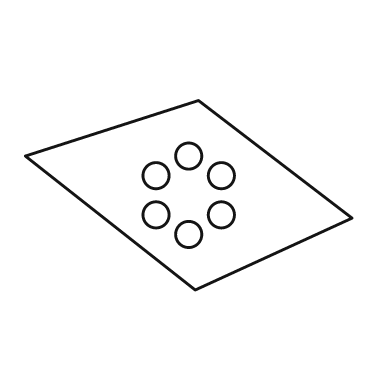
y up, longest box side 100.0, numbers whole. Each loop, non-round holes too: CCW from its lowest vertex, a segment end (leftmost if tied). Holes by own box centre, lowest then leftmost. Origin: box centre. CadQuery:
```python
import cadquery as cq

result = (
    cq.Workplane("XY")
    .moveTo(2.0, -29.0)
    .lineTo(50.0, -7.0)
    .lineTo(3.0, 29.0)
    .lineTo(-50.0, 12.0)
    .close()
    .moveTo(0.0, -12.0)
    .circle(4.0)
    .moveTo(-10.0, -6.0)
    .circle(4.0)
    .moveTo(10.0, -6.0)
    .circle(4.0)
    .moveTo(-10.0, 6.0)
    .circle(4.0)
    .moveTo(10.0, 6.0)
    .circle(4.0)
    .moveTo(0.0, 12.0)
    .circle(4.0)
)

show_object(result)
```